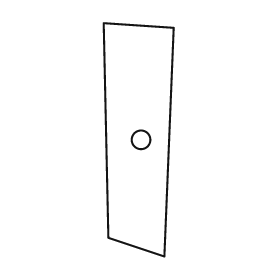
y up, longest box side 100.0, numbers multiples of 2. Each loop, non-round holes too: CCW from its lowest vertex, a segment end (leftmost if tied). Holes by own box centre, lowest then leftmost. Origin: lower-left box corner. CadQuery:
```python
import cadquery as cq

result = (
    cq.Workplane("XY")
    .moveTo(26.0, 0.0)
    .lineTo(30.0, 98.0)
    .lineTo(0.0, 100.0)
    .lineTo(2.0, 8.0)
    .close()
    .moveTo(16.0, 50.0)
    .circle(4.0)
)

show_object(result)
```